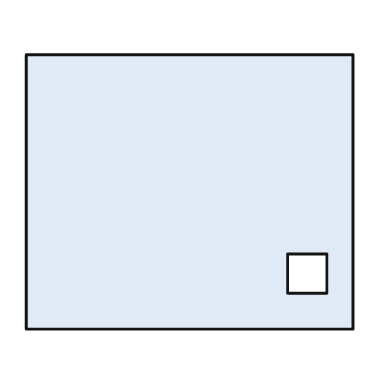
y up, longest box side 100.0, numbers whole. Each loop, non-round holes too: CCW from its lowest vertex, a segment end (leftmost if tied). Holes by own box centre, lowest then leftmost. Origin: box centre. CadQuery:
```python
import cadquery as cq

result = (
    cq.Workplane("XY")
    .moveTo(-50.0, -42.0)
    .lineTo(50.0, -42.0)
    .lineTo(50.0, 42.0)
    .lineTo(-50.0, 42.0)
    .close()
    .moveTo(30.0, -31.0)
    .lineTo(42.0, -31.0)
    .lineTo(42.0, -19.0)
    .lineTo(30.0, -19.0)
    .close()
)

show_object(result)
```